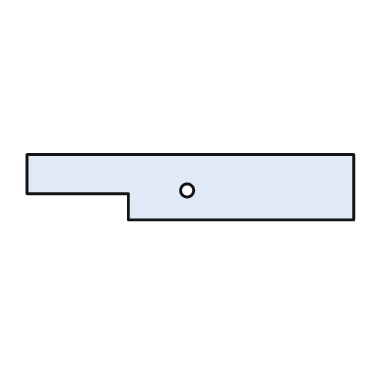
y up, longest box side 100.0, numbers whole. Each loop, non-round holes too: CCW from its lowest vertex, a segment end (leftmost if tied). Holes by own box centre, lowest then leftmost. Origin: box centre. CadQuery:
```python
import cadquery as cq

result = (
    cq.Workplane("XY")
    .moveTo(-19.0, -10.0)
    .lineTo(50.0, -10.0)
    .lineTo(50.0, 10.0)
    .lineTo(-50.0, 10.0)
    .lineTo(-50.0, -2.0)
    .lineTo(-19.0, -2.0)
    .close()
    .moveTo(-1.0, -1.0)
    .circle(2.0)
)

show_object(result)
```